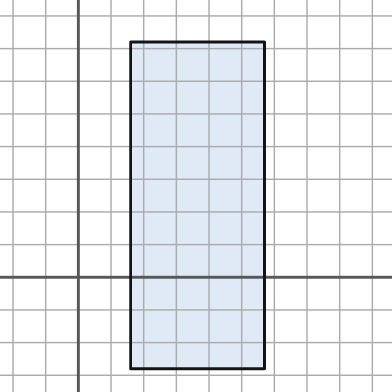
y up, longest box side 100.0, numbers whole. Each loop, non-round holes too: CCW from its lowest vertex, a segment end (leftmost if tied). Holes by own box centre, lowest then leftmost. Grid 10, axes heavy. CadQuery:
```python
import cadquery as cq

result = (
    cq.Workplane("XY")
    .moveTo(16.0, -28.0)
    .lineTo(57.0, -28.0)
    .lineTo(57.0, 72.0)
    .lineTo(16.0, 72.0)
    .close()
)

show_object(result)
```